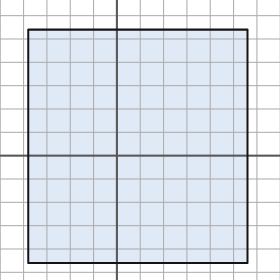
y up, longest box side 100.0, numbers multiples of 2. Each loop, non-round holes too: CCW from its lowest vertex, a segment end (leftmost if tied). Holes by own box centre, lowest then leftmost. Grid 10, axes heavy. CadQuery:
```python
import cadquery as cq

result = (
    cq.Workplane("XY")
    .moveTo(-38.0, -46.0)
    .lineTo(56.0, -46.0)
    .lineTo(56.0, 54.0)
    .lineTo(-38.0, 54.0)
    .close()
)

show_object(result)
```